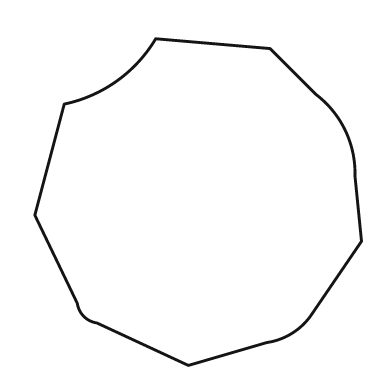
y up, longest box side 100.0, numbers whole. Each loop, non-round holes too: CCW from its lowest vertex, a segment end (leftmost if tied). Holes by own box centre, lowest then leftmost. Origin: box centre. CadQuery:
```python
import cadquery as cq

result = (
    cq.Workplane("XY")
    .moveTo(-3.0, -50.0)
    .lineTo(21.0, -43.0)
    .threePointArc((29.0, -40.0), (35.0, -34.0))
    .lineTo(50.0, -12.0)
    .lineTo(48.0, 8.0)
    .threePointArc((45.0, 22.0), (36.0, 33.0))
    .lineTo(22.0, 47.0)
    .lineTo(-13.0, 50.0)
    .threePointArc((-25.0, 37.0), (-41.0, 30.0))
    .lineTo(-50.0, -4.0)
    .lineTo(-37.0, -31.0)
    .threePointArc((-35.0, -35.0), (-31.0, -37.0))
    .close()
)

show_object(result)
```